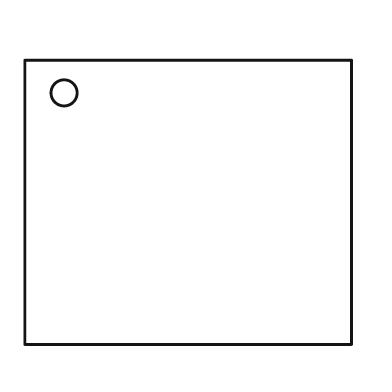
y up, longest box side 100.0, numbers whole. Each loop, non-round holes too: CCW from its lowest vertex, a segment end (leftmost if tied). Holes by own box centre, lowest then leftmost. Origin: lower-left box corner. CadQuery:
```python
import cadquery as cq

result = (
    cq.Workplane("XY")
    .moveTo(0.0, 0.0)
    .lineTo(100.0, 0.0)
    .lineTo(100.0, 87.0)
    .lineTo(0.0, 87.0)
    .close()
    .moveTo(12.0, 77.0)
    .circle(4.0)
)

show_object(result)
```